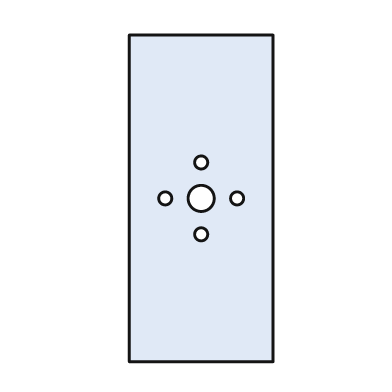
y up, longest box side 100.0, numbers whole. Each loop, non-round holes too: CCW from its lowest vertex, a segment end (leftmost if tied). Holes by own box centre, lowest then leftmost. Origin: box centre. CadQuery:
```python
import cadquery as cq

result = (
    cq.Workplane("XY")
    .moveTo(-22.0, -50.0)
    .lineTo(22.0, -50.0)
    .lineTo(22.0, 50.0)
    .lineTo(-22.0, 50.0)
    .close()
    .moveTo(0.0, -11.0)
    .circle(2.0)
    .moveTo(-11.0, 0.0)
    .circle(2.0)
    .moveTo(0.0, 0.0)
    .circle(4.0)
    .moveTo(11.0, 0.0)
    .circle(2.0)
    .moveTo(0.0, 11.0)
    .circle(2.0)
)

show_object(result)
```